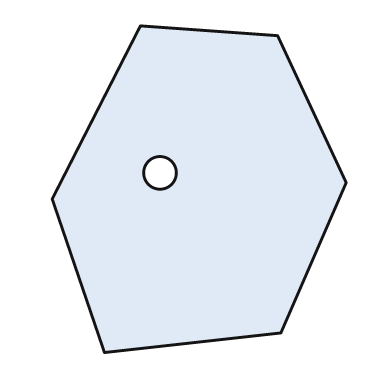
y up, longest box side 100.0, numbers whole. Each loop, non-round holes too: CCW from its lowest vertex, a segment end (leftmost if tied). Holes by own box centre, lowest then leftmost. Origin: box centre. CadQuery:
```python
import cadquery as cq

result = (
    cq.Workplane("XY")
    .moveTo(-29.0, -50.0)
    .lineTo(25.0, -44.0)
    .lineTo(45.0, 2.0)
    .lineTo(24.0, 47.0)
    .lineTo(-18.0, 50.0)
    .lineTo(-45.0, -3.0)
    .close()
    .moveTo(-12.0, 5.0)
    .circle(5.0)
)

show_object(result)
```